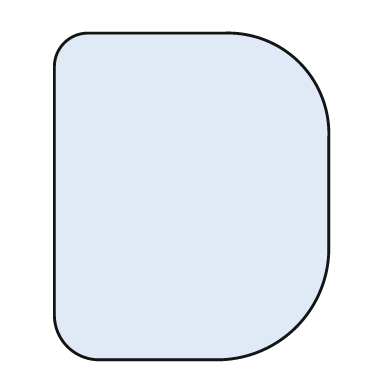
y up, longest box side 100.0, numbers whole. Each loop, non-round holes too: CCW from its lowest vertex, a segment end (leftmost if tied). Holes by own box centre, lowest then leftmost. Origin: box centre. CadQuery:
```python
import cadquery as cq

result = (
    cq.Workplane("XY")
    .moveTo(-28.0, -50.0)
    .lineTo(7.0, -50.0)
    .threePointArc((32.0, -40.0), (42.0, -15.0))
    .lineTo(42.0, 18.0)
    .threePointArc((33.0, 41.0), (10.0, 50.0))
    .lineTo(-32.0, 50.0)
    .threePointArc((-39.0, 47.0), (-42.0, 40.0))
    .lineTo(-42.0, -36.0)
    .threePointArc((-38.0, -46.0), (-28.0, -50.0))
    .close()
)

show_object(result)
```